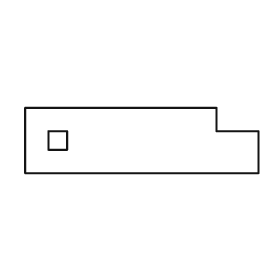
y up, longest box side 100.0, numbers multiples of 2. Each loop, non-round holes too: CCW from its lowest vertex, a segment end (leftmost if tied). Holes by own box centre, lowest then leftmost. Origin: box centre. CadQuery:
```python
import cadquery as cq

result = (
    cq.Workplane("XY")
    .moveTo(-50.0, -14.0)
    .lineTo(50.0, -14.0)
    .lineTo(50.0, 4.0)
    .lineTo(32.0, 4.0)
    .lineTo(32.0, 14.0)
    .lineTo(-50.0, 14.0)
    .close()
    .moveTo(-40.0, -4.0)
    .lineTo(-32.0, -4.0)
    .lineTo(-32.0, 4.0)
    .lineTo(-40.0, 4.0)
    .close()
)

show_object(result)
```